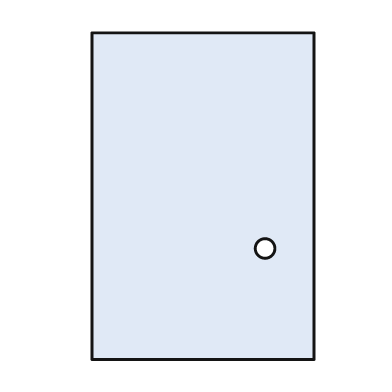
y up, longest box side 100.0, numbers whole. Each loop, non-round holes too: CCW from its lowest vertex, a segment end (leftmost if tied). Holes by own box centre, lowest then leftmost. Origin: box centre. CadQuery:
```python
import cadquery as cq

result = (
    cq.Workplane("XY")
    .moveTo(-34.0, -50.0)
    .lineTo(34.0, -50.0)
    .lineTo(34.0, 50.0)
    .lineTo(-34.0, 50.0)
    .close()
    .moveTo(19.0, -16.0)
    .circle(3.0)
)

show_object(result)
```